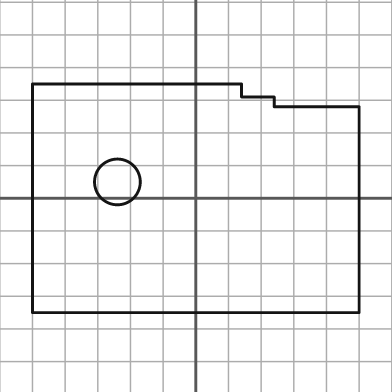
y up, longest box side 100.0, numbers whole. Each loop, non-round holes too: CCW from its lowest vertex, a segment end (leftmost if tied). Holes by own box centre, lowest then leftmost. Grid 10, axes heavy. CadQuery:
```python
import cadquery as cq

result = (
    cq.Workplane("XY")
    .moveTo(-50.0, -35.0)
    .lineTo(50.0, -35.0)
    .lineTo(50.0, 28.0)
    .lineTo(24.0, 28.0)
    .lineTo(24.0, 31.0)
    .lineTo(14.0, 31.0)
    .lineTo(14.0, 35.0)
    .lineTo(-50.0, 35.0)
    .close()
    .moveTo(-24.0, 5.0)
    .circle(7.0)
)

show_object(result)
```